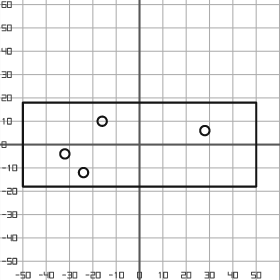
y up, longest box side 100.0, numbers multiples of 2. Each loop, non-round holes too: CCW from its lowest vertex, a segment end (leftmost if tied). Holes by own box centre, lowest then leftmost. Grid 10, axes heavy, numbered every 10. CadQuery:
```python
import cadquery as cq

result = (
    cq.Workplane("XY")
    .moveTo(-50.0, -18.0)
    .lineTo(50.0, -18.0)
    .lineTo(50.0, 18.0)
    .lineTo(-50.0, 18.0)
    .close()
    .moveTo(-24.0, -12.0)
    .circle(2.0)
    .moveTo(-32.0, -4.0)
    .circle(2.0)
    .moveTo(28.0, 6.0)
    .circle(2.0)
    .moveTo(-16.0, 10.0)
    .circle(2.0)
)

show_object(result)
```